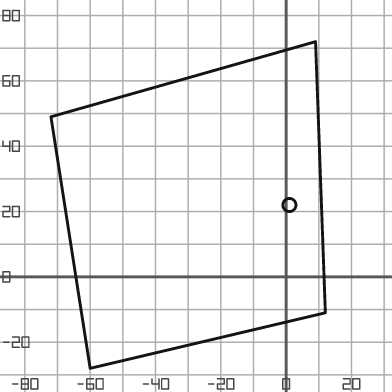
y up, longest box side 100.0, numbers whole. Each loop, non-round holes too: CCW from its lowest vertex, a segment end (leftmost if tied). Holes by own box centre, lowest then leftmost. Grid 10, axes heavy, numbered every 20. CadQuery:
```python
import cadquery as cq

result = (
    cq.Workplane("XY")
    .moveTo(-60.0, -28.0)
    .lineTo(12.0, -11.0)
    .lineTo(9.0, 72.0)
    .lineTo(-72.0, 49.0)
    .close()
    .moveTo(1.0, 22.0)
    .circle(2.0)
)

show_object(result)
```